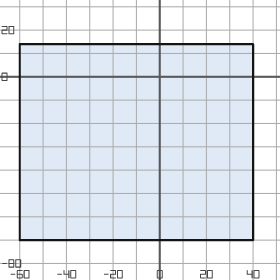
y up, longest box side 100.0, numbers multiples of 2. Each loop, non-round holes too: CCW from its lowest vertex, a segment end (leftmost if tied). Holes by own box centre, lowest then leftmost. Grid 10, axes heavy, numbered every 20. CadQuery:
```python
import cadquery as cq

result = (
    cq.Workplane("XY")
    .moveTo(-60.0, -70.0)
    .lineTo(40.0, -70.0)
    .lineTo(40.0, 14.0)
    .lineTo(-60.0, 14.0)
    .close()
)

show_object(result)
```